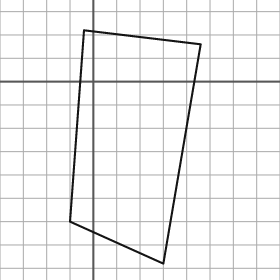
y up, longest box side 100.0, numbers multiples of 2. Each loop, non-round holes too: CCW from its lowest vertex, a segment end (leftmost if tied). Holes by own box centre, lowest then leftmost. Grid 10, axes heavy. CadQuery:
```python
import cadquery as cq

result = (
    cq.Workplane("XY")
    .moveTo(30.0, -78.0)
    .lineTo(46.0, 16.0)
    .lineTo(-4.0, 22.0)
    .lineTo(-10.0, -60.0)
    .close()
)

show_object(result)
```